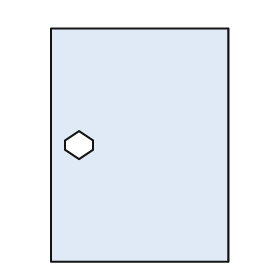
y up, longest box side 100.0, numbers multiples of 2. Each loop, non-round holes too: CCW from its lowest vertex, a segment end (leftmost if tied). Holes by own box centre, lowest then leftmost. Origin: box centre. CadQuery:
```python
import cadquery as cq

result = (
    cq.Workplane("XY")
    .moveTo(-38.0, -50.0)
    .lineTo(38.0, -50.0)
    .lineTo(38.0, 50.0)
    .lineTo(-38.0, 50.0)
    .close()
    .moveTo(-26.0, -6.0)
    .lineTo(-20.0, -2.0)
    .lineTo(-20.0, 2.0)
    .lineTo(-26.0, 6.0)
    .lineTo(-32.0, 2.0)
    .lineTo(-32.0, -2.0)
    .close()
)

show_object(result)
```